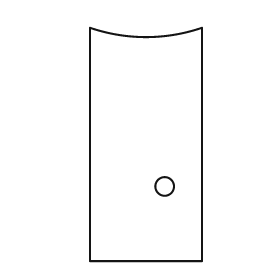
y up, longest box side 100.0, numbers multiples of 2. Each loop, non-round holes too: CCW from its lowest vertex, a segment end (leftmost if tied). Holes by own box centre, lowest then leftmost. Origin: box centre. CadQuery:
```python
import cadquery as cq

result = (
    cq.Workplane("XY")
    .moveTo(-24.0, -50.0)
    .lineTo(24.0, -50.0)
    .lineTo(24.0, 50.0)
    .threePointArc((0.0, 46.0), (-24.0, 50.0))
    .close()
    .moveTo(8.0, -18.0)
    .circle(4.0)
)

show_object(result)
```